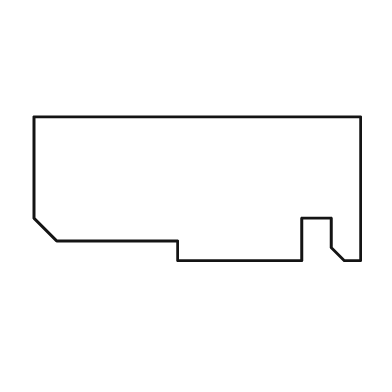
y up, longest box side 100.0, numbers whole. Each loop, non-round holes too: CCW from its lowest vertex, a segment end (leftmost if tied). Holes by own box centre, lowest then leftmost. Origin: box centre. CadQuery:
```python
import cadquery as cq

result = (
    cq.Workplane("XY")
    .moveTo(-6.0, -22.0)
    .lineTo(32.0, -22.0)
    .lineTo(32.0, -9.0)
    .lineTo(41.0, -9.0)
    .lineTo(41.0, -18.0)
    .lineTo(45.0, -22.0)
    .lineTo(50.0, -22.0)
    .lineTo(50.0, 22.0)
    .lineTo(-50.0, 22.0)
    .lineTo(-50.0, -9.0)
    .lineTo(-43.0, -16.0)
    .lineTo(-6.0, -16.0)
    .close()
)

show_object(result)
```